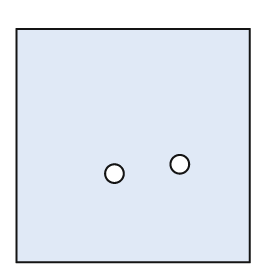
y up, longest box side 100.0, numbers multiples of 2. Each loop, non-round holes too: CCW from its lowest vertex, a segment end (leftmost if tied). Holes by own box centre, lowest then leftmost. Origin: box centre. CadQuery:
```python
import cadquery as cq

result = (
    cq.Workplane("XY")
    .moveTo(-50.0, -50.0)
    .lineTo(50.0, -50.0)
    .lineTo(50.0, 50.0)
    .lineTo(-50.0, 50.0)
    .close()
    .moveTo(-8.0, -12.0)
    .circle(4.0)
    .moveTo(20.0, -8.0)
    .circle(4.0)
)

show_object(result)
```